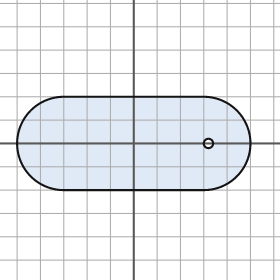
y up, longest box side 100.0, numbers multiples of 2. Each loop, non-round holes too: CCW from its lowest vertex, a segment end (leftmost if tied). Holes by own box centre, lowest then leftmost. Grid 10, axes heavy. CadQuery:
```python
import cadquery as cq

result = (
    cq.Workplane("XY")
    .moveTo(-30.0, -20.0)
    .lineTo(30.0, -20.0)
    .threePointArc((50.0, 0.0), (30.0, 20.0))
    .lineTo(-30.0, 20.0)
    .threePointArc((-50.0, 0.0), (-30.0, -20.0))
    .close()
    .moveTo(32.0, 0.0)
    .circle(2.0)
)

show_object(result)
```